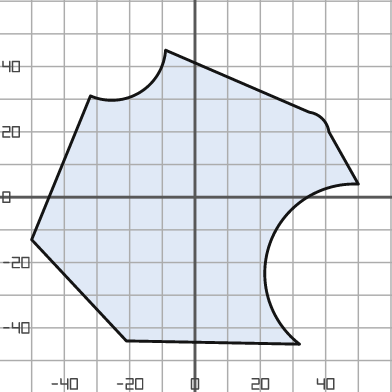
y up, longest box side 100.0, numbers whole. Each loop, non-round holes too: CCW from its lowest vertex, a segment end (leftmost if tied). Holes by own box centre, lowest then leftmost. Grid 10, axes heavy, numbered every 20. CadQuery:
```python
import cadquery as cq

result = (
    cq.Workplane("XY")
    .moveTo(32.0, -45.0)
    .threePointArc((23.0, -14.0), (50.0, 4.0))
    .lineTo(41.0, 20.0)
    .threePointArc((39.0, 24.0), (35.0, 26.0))
    .lineTo(-9.0, 45.0)
    .threePointArc((-17.0, 32.0), (-32.0, 31.0))
    .lineTo(-50.0, -13.0)
    .lineTo(-21.0, -44.0)
    .close()
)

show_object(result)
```